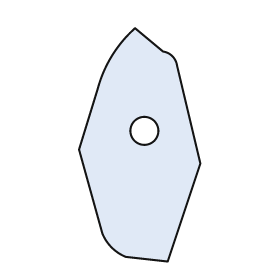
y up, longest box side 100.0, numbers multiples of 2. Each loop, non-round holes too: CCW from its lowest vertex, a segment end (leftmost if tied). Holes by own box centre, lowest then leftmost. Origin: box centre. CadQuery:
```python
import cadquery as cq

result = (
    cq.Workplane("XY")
    .moveTo(12.0, -50.0)
    .lineTo(26.0, -8.0)
    .lineTo(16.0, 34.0)
    .threePointArc((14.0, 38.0), (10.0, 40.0))
    .lineTo(-2.0, 50.0)
    .threePointArc((-12.0, 38.0), (-18.0, 24.0))
    .lineTo(-26.0, -2.0)
    .lineTo(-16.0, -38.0)
    .threePointArc((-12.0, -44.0), (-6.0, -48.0))
    .close()
    .moveTo(2.0, 6.0)
    .circle(6.0)
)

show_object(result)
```